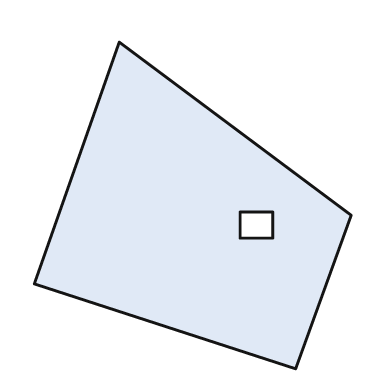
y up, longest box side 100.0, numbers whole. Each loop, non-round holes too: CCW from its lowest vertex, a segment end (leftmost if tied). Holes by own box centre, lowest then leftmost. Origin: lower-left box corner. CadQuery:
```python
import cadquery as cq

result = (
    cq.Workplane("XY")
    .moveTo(80.0, 0.0)
    .lineTo(97.0, 47.0)
    .lineTo(26.0, 100.0)
    .lineTo(0.0, 26.0)
    .close()
    .moveTo(63.0, 40.0)
    .lineTo(73.0, 40.0)
    .lineTo(73.0, 48.0)
    .lineTo(63.0, 48.0)
    .close()
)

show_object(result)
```